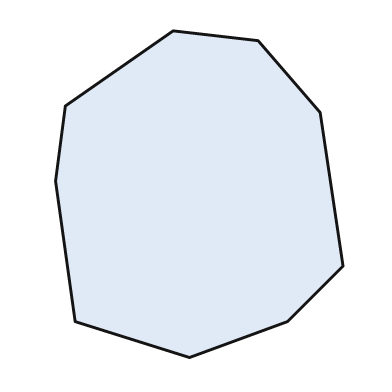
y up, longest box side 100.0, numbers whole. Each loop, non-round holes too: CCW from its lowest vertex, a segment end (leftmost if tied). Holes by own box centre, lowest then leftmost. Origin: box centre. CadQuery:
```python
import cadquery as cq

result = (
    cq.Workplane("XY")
    .moveTo(-3.0, -50.0)
    .lineTo(27.0, -39.0)
    .lineTo(44.0, -22.0)
    .lineTo(37.0, 25.0)
    .lineTo(18.0, 47.0)
    .lineTo(-8.0, 50.0)
    .lineTo(-41.0, 27.0)
    .lineTo(-44.0, 4.0)
    .lineTo(-38.0, -39.0)
    .close()
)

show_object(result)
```